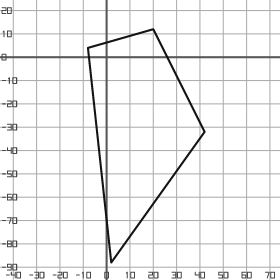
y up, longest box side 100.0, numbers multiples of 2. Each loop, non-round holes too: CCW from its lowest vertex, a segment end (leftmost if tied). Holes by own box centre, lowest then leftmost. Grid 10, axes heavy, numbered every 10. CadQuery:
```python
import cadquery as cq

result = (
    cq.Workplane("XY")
    .moveTo(2.0, -88.0)
    .lineTo(42.0, -32.0)
    .lineTo(20.0, 12.0)
    .lineTo(-8.0, 4.0)
    .close()
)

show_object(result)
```